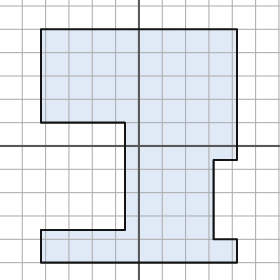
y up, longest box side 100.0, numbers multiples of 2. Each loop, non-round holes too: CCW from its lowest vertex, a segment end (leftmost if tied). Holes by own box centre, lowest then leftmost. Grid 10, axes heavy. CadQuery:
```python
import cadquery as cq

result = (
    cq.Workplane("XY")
    .moveTo(-42.0, -50.0)
    .lineTo(42.0, -50.0)
    .lineTo(42.0, -40.0)
    .lineTo(32.0, -40.0)
    .lineTo(32.0, -6.0)
    .lineTo(42.0, -6.0)
    .lineTo(42.0, 50.0)
    .lineTo(-42.0, 50.0)
    .lineTo(-42.0, 10.0)
    .lineTo(-6.0, 10.0)
    .lineTo(-6.0, -36.0)
    .lineTo(-42.0, -36.0)
    .close()
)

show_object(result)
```